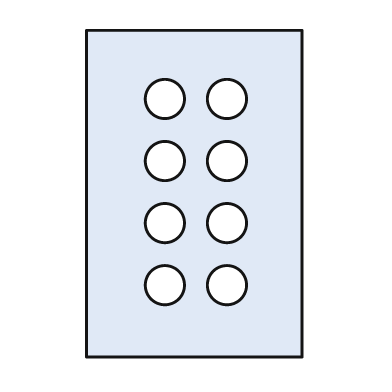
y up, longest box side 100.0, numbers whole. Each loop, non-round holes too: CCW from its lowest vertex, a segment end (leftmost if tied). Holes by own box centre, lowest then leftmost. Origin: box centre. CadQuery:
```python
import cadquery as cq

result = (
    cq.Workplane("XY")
    .moveTo(-33.0, -50.0)
    .lineTo(33.0, -50.0)
    .lineTo(33.0, 50.0)
    .lineTo(-33.0, 50.0)
    .close()
    .moveTo(-9.0, -28.0)
    .circle(6.0)
    .moveTo(10.0, -28.0)
    .circle(6.0)
    .moveTo(-9.0, -9.0)
    .circle(6.0)
    .moveTo(10.0, -9.0)
    .circle(6.0)
    .moveTo(-9.0, 10.0)
    .circle(6.0)
    .moveTo(10.0, 10.0)
    .circle(6.0)
    .moveTo(-9.0, 29.0)
    .circle(6.0)
    .moveTo(10.0, 29.0)
    .circle(6.0)
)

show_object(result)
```